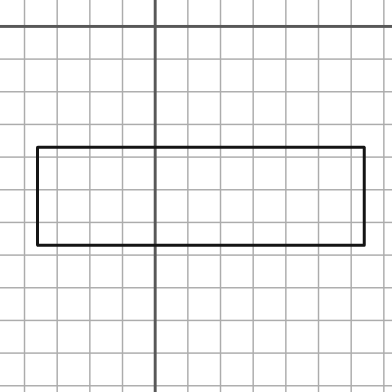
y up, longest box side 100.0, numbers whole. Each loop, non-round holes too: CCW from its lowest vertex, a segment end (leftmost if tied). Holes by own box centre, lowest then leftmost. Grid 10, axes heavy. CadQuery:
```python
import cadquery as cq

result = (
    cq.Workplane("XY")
    .moveTo(-36.0, -67.0)
    .lineTo(64.0, -67.0)
    .lineTo(64.0, -37.0)
    .lineTo(-36.0, -37.0)
    .close()
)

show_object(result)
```